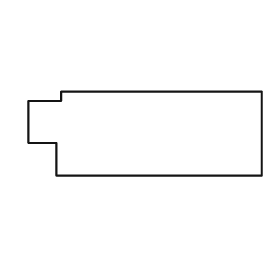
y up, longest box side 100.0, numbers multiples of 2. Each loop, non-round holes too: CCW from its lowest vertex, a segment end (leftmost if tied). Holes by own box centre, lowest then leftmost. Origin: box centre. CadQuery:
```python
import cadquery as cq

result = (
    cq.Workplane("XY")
    .moveTo(-38.0, -18.0)
    .lineTo(50.0, -18.0)
    .lineTo(50.0, 18.0)
    .lineTo(-36.0, 18.0)
    .lineTo(-36.0, 14.0)
    .lineTo(-50.0, 14.0)
    .lineTo(-50.0, -4.0)
    .lineTo(-38.0, -4.0)
    .close()
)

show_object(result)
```